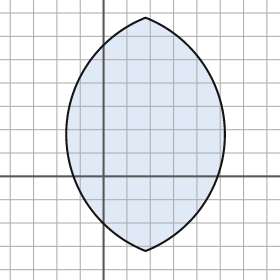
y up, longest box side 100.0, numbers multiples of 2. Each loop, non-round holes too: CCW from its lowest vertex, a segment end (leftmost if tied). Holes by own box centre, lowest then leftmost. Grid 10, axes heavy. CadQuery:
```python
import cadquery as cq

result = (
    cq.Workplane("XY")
    .moveTo(18.0, -32.0)
    .threePointArc((52.0, 18.0), (18.0, 68.0))
    .threePointArc((-16.0, 18.0), (18.0, -32.0))
    .close()
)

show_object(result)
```